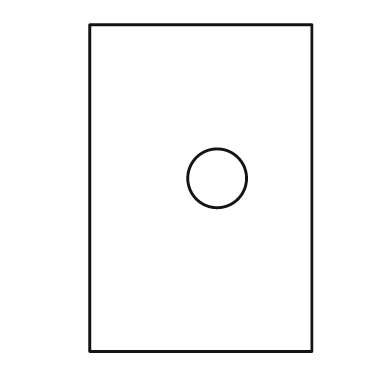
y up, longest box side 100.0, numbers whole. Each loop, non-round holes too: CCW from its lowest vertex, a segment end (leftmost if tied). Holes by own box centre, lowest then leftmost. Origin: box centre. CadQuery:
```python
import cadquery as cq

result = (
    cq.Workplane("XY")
    .moveTo(-34.0, -50.0)
    .lineTo(34.0, -50.0)
    .lineTo(34.0, 50.0)
    .lineTo(-34.0, 50.0)
    .close()
    .moveTo(5.0, 3.0)
    .circle(9.0)
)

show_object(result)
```